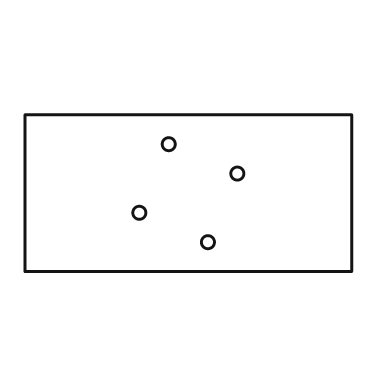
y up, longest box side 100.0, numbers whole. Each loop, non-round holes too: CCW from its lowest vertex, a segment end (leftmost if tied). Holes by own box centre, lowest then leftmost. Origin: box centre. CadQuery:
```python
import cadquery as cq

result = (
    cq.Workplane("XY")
    .moveTo(-50.0, -24.0)
    .lineTo(50.0, -24.0)
    .lineTo(50.0, 24.0)
    .lineTo(-50.0, 24.0)
    .close()
    .moveTo(6.0, -15.0)
    .circle(2.0)
    .moveTo(-15.0, -6.0)
    .circle(2.0)
    .moveTo(15.0, 6.0)
    .circle(2.0)
    .moveTo(-6.0, 15.0)
    .circle(2.0)
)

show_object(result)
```